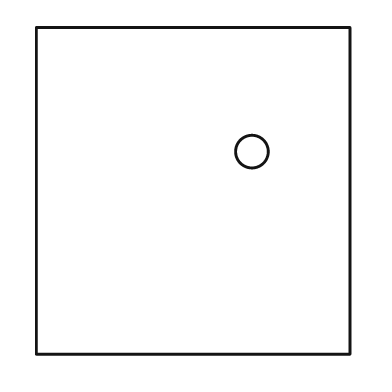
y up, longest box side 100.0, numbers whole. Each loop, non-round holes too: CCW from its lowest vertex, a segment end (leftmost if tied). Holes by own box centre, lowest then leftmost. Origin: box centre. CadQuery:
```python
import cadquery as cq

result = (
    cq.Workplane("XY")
    .moveTo(-48.0, -50.0)
    .lineTo(48.0, -50.0)
    .lineTo(48.0, 50.0)
    .lineTo(-48.0, 50.0)
    .close()
    .moveTo(18.0, 12.0)
    .circle(5.0)
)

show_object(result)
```